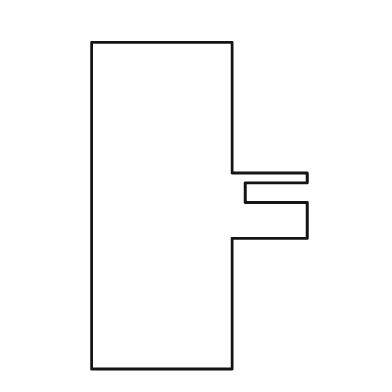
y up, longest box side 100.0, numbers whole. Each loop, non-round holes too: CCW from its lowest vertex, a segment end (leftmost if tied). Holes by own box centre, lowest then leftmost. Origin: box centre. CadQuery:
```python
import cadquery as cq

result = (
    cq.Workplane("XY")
    .moveTo(-33.0, -50.0)
    .lineTo(10.0, -50.0)
    .lineTo(10.0, -10.0)
    .lineTo(33.0, -10.0)
    .lineTo(33.0, 1.0)
    .lineTo(14.0, 1.0)
    .lineTo(14.0, 7.0)
    .lineTo(33.0, 7.0)
    .lineTo(33.0, 10.0)
    .lineTo(10.0, 10.0)
    .lineTo(10.0, 50.0)
    .lineTo(-33.0, 50.0)
    .close()
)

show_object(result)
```